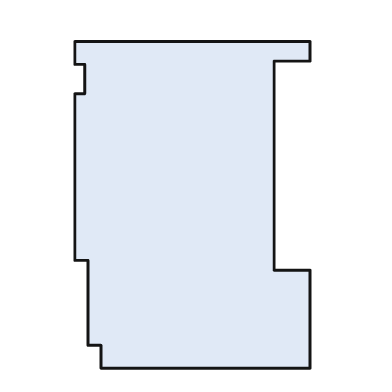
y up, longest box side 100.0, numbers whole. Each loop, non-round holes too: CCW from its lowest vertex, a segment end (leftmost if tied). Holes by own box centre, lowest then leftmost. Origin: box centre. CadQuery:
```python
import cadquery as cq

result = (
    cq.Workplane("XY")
    .moveTo(-28.0, -50.0)
    .lineTo(36.0, -50.0)
    .lineTo(36.0, -20.0)
    .lineTo(25.0, -20.0)
    .lineTo(25.0, 44.0)
    .lineTo(36.0, 44.0)
    .lineTo(36.0, 50.0)
    .lineTo(-36.0, 50.0)
    .lineTo(-36.0, 43.0)
    .lineTo(-33.0, 43.0)
    .lineTo(-33.0, 34.0)
    .lineTo(-36.0, 34.0)
    .lineTo(-36.0, -17.0)
    .lineTo(-32.0, -17.0)
    .lineTo(-32.0, -43.0)
    .lineTo(-28.0, -43.0)
    .close()
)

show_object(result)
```